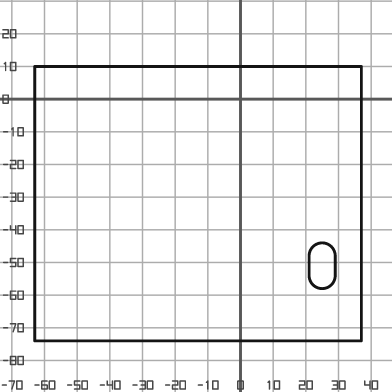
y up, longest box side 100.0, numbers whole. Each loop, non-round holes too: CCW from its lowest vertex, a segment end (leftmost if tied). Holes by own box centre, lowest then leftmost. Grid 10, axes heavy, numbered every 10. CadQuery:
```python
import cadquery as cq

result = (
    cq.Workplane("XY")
    .moveTo(-63.0, -74.0)
    .lineTo(37.0, -74.0)
    .lineTo(37.0, 10.0)
    .lineTo(-63.0, 10.0)
    .close()
    .moveTo(21.0, -54.0)
    .threePointArc((25.0, -58.0), (29.0, -54.0))
    .lineTo(29.0, -48.0)
    .threePointArc((25.0, -44.0), (21.0, -48.0))
    .close()
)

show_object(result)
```